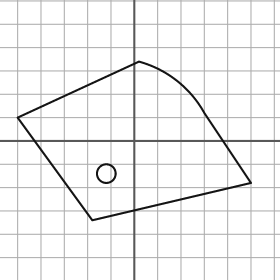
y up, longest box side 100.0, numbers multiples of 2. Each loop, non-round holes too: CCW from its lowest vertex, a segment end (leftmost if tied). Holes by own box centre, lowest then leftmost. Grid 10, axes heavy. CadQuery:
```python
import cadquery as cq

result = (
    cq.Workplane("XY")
    .moveTo(-18.0, -34.0)
    .lineTo(50.0, -18.0)
    .lineTo(30.0, 12.0)
    .threePointArc((18.0, 26.0), (2.0, 34.0))
    .lineTo(-50.0, 10.0)
    .close()
    .moveTo(-12.0, -14.0)
    .circle(4.0)
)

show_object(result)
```